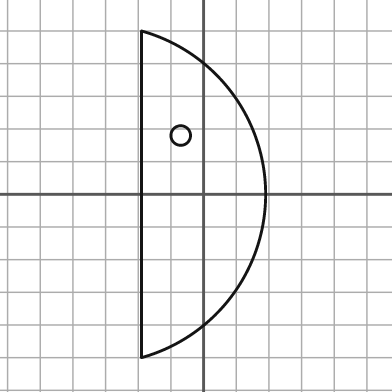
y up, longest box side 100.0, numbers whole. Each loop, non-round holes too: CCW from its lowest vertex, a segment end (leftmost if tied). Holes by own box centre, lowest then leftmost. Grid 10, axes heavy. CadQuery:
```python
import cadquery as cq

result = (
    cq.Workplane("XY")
    .moveTo(-19.0, -50.0)
    .threePointArc((19.0, 0.0), (-19.0, 50.0))
    .close()
    .moveTo(-7.0, 18.0)
    .circle(3.0)
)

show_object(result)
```